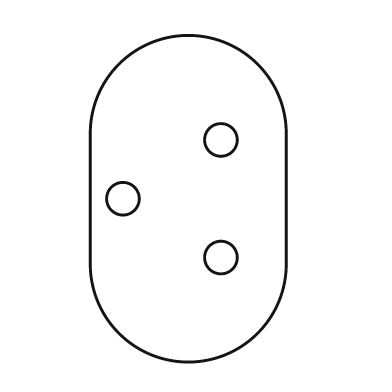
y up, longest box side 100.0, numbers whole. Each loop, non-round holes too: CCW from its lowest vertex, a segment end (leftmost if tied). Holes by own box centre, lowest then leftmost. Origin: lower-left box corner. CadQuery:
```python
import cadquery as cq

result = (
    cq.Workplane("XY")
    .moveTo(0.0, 30.0)
    .threePointArc((30.0, 0.0), (60.0, 30.0))
    .lineTo(60.0, 70.0)
    .threePointArc((30.0, 100.0), (0.0, 70.0))
    .close()
    .moveTo(40.0, 32.0)
    .circle(5.0)
    .moveTo(10.0, 50.0)
    .circle(5.0)
    .moveTo(40.0, 68.0)
    .circle(5.0)
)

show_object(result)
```